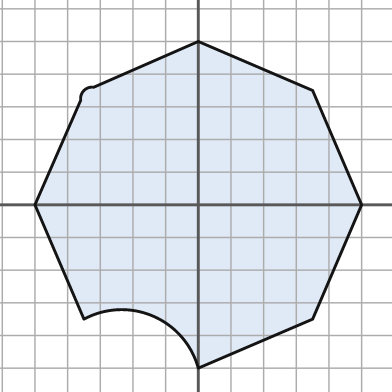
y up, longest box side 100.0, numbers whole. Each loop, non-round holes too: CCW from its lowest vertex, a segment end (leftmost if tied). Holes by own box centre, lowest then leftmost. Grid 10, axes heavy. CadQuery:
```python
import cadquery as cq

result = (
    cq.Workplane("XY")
    .moveTo(0.0, -50.0)
    .lineTo(35.0, -35.0)
    .lineTo(50.0, 0.0)
    .lineTo(35.0, 35.0)
    .lineTo(0.0, 50.0)
    .lineTo(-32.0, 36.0)
    .threePointArc((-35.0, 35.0), (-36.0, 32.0))
    .lineTo(-50.0, 0.0)
    .lineTo(-35.0, -35.0)
    .threePointArc((-14.0, -34.0), (0.0, -50.0))
    .close()
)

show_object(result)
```